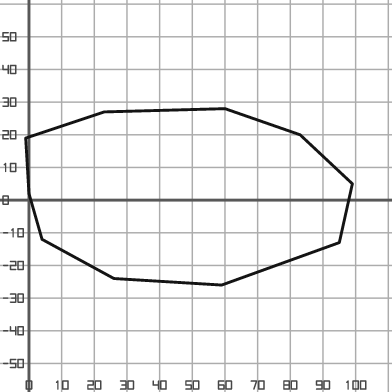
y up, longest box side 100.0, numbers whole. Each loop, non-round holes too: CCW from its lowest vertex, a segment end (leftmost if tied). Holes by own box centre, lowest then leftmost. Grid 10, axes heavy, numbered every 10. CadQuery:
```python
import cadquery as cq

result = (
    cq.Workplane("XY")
    .moveTo(59.0, -26.0)
    .lineTo(95.0, -13.0)
    .lineTo(99.0, 5.0)
    .lineTo(83.0, 20.0)
    .lineTo(60.0, 28.0)
    .lineTo(23.0, 27.0)
    .lineTo(-1.0, 19.0)
    .lineTo(0.0, 2.0)
    .lineTo(4.0, -12.0)
    .lineTo(26.0, -24.0)
    .close()
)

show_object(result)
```